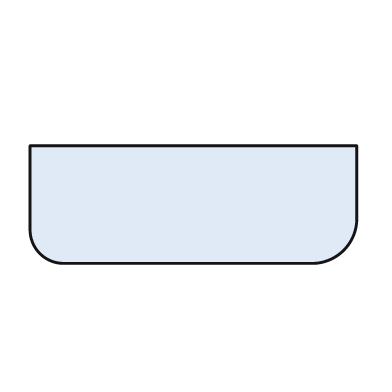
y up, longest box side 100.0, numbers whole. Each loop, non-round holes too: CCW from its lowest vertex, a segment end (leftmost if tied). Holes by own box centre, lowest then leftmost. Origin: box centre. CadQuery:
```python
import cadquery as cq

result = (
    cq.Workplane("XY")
    .moveTo(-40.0, -18.0)
    .lineTo(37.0, -18.0)
    .threePointArc((46.0, -14.0), (50.0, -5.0))
    .lineTo(50.0, 18.0)
    .lineTo(-50.0, 18.0)
    .lineTo(-50.0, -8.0)
    .threePointArc((-47.0, -15.0), (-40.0, -18.0))
    .close()
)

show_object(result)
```